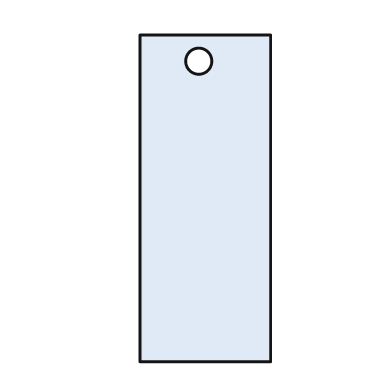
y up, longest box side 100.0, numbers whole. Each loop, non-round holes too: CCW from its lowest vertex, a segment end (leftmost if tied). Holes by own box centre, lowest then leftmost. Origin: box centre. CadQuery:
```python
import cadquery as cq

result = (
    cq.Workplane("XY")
    .moveTo(-20.0, -50.0)
    .lineTo(20.0, -50.0)
    .lineTo(20.0, 50.0)
    .lineTo(-20.0, 50.0)
    .close()
    .moveTo(-2.0, 42.0)
    .circle(4.0)
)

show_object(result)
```